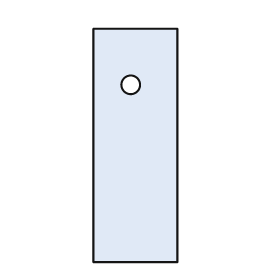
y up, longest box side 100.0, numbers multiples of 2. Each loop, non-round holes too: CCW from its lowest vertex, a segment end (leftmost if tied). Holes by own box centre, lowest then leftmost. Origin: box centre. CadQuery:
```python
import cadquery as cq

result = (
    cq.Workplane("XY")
    .moveTo(-18.0, -50.0)
    .lineTo(18.0, -50.0)
    .lineTo(18.0, 50.0)
    .lineTo(-18.0, 50.0)
    .close()
    .moveTo(-2.0, 26.0)
    .circle(4.0)
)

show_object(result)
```